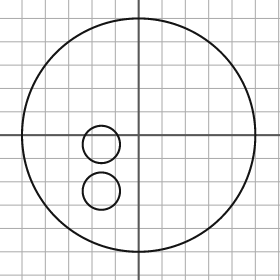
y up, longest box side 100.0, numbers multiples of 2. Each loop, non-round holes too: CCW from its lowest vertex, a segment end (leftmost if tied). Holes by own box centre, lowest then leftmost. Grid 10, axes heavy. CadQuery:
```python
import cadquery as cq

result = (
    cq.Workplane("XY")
    .moveTo(0.0, 0.0)
    .circle(50.0)
    .moveTo(-16.0, -24.0)
    .circle(8.0)
    .moveTo(-16.0, -4.0)
    .circle(8.0)
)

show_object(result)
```